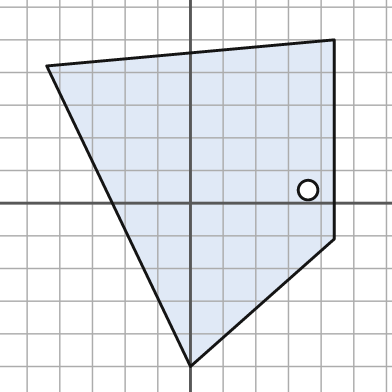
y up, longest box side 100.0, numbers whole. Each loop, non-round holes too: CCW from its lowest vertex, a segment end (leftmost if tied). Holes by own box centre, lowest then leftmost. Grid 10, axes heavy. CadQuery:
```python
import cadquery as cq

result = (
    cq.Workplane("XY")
    .moveTo(0.0, -50.0)
    .lineTo(44.0, -11.0)
    .lineTo(44.0, 50.0)
    .lineTo(-44.0, 42.0)
    .close()
    .moveTo(36.0, 4.0)
    .circle(3.0)
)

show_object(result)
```